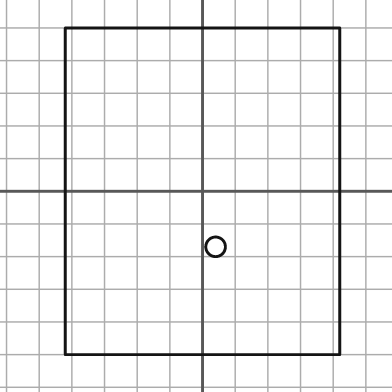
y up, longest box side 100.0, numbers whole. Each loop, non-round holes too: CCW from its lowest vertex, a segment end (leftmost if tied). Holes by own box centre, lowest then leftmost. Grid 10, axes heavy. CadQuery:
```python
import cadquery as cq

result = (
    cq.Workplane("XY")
    .moveTo(-42.0, -50.0)
    .lineTo(42.0, -50.0)
    .lineTo(42.0, 50.0)
    .lineTo(-42.0, 50.0)
    .close()
    .moveTo(4.0, -17.0)
    .circle(3.0)
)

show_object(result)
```